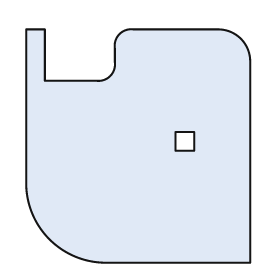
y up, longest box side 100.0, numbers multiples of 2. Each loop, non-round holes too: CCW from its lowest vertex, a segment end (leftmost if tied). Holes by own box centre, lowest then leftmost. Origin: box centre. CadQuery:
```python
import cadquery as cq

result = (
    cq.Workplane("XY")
    .moveTo(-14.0, -50.0)
    .lineTo(48.0, -50.0)
    .lineTo(48.0, 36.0)
    .threePointArc((44.0, 46.0), (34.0, 50.0))
    .lineTo(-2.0, 50.0)
    .threePointArc((-8.0, 48.0), (-10.0, 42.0))
    .lineTo(-10.0, 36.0)
    .threePointArc((-12.0, 30.0), (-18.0, 28.0))
    .lineTo(-40.0, 28.0)
    .lineTo(-40.0, 50.0)
    .lineTo(-48.0, 50.0)
    .lineTo(-48.0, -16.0)
    .threePointArc((-38.0, -40.0), (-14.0, -50.0))
    .close()
    .moveTo(16.0, -2.0)
    .lineTo(24.0, -2.0)
    .lineTo(24.0, 6.0)
    .lineTo(16.0, 6.0)
    .close()
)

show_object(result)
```